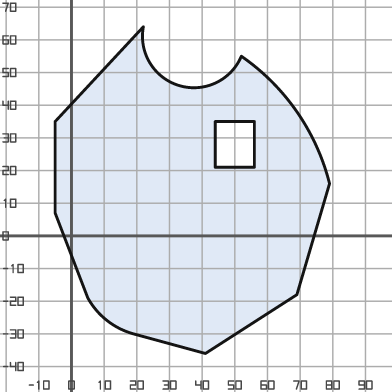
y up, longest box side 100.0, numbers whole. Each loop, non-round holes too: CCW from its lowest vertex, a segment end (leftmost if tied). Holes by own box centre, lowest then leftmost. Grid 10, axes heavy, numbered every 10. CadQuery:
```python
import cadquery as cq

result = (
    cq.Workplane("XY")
    .moveTo(41.0, -36.0)
    .lineTo(69.0, -18.0)
    .lineTo(79.0, 16.0)
    .threePointArc((69.0, 38.0), (52.0, 55.0))
    .threePointArc((33.0, 46.0), (22.0, 64.0))
    .lineTo(-5.0, 35.0)
    .lineTo(-5.0, 7.0)
    .lineTo(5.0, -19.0)
    .threePointArc((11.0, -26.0), (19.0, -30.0))
    .close()
    .moveTo(44.0, 21.0)
    .lineTo(56.0, 21.0)
    .lineTo(56.0, 35.0)
    .lineTo(44.0, 35.0)
    .close()
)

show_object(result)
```